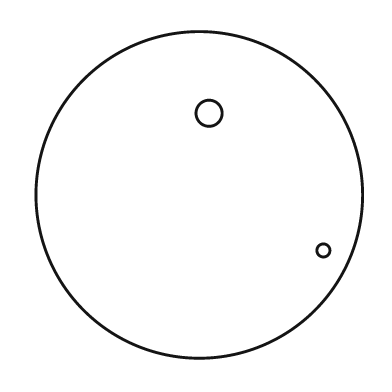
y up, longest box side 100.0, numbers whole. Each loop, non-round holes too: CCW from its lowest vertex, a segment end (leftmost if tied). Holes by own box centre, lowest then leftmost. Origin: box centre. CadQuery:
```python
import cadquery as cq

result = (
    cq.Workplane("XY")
    .moveTo(0.0, 0.0)
    .circle(50.0)
    .moveTo(38.0, -17.0)
    .circle(2.0)
    .moveTo(3.0, 25.0)
    .circle(4.0)
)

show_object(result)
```